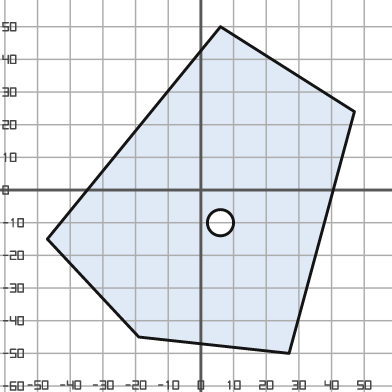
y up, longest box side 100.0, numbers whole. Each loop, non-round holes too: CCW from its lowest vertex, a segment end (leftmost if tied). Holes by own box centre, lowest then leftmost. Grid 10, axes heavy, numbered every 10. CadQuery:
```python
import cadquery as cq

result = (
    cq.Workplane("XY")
    .moveTo(27.0, -50.0)
    .lineTo(47.0, 24.0)
    .lineTo(6.0, 50.0)
    .lineTo(-47.0, -15.0)
    .lineTo(-19.0, -45.0)
    .close()
    .moveTo(6.0, -10.0)
    .circle(4.0)
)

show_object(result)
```